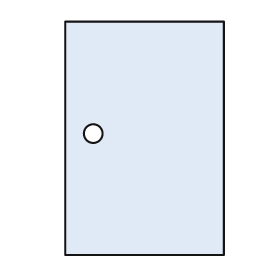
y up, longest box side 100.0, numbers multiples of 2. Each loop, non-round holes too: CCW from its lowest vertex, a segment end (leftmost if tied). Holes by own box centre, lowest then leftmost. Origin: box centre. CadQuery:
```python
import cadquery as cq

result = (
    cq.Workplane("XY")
    .moveTo(-34.0, -50.0)
    .lineTo(34.0, -50.0)
    .lineTo(34.0, 50.0)
    .lineTo(-34.0, 50.0)
    .close()
    .moveTo(-22.0, 2.0)
    .circle(4.0)
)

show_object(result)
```